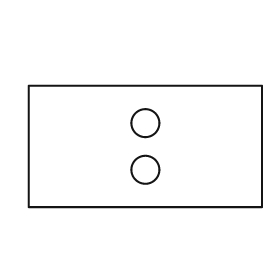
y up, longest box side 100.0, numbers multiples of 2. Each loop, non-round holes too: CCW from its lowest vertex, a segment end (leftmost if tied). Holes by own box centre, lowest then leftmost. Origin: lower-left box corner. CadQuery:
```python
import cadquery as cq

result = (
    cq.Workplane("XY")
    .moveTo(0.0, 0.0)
    .lineTo(100.0, 0.0)
    .lineTo(100.0, 52.0)
    .lineTo(0.0, 52.0)
    .close()
    .moveTo(50.0, 16.0)
    .circle(6.0)
    .moveTo(50.0, 36.0)
    .circle(6.0)
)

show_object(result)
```